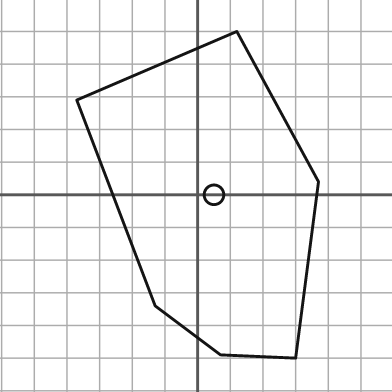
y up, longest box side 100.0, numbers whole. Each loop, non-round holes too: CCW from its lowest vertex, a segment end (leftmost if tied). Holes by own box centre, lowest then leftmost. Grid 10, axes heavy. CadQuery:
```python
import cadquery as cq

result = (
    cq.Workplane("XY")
    .moveTo(30.0, -50.0)
    .lineTo(37.0, 4.0)
    .lineTo(12.0, 50.0)
    .lineTo(-37.0, 29.0)
    .lineTo(-13.0, -34.0)
    .lineTo(7.0, -49.0)
    .close()
    .moveTo(5.0, 0.0)
    .circle(3.0)
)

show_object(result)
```